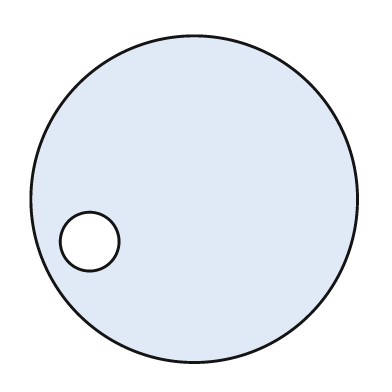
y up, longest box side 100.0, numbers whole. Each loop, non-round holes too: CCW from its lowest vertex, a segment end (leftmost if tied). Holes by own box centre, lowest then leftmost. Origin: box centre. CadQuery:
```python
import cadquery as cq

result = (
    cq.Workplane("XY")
    .moveTo(0.0, 0.0)
    .circle(50.0)
    .moveTo(-32.0, -13.0)
    .circle(9.0)
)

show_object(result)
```